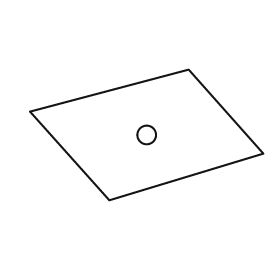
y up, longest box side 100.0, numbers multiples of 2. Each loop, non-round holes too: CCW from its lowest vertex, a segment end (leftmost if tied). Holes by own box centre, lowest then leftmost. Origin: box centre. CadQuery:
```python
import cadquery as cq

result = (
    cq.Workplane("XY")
    .moveTo(-16.0, -28.0)
    .lineTo(50.0, -8.0)
    .lineTo(18.0, 28.0)
    .lineTo(-50.0, 10.0)
    .close()
    .moveTo(0.0, 0.0)
    .circle(4.0)
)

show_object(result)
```